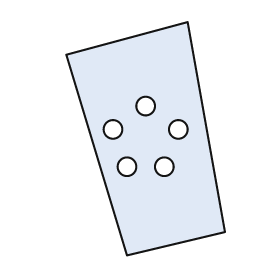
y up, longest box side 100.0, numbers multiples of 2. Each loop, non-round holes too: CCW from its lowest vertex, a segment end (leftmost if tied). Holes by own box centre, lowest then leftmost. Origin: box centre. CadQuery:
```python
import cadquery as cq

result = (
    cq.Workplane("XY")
    .moveTo(-8.0, -50.0)
    .lineTo(34.0, -40.0)
    .lineTo(18.0, 50.0)
    .lineTo(-34.0, 36.0)
    .close()
    .moveTo(-8.0, -12.0)
    .circle(4.0)
    .moveTo(8.0, -12.0)
    .circle(4.0)
    .moveTo(-14.0, 4.0)
    .circle(4.0)
    .moveTo(14.0, 4.0)
    .circle(4.0)
    .moveTo(0.0, 14.0)
    .circle(4.0)
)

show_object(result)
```